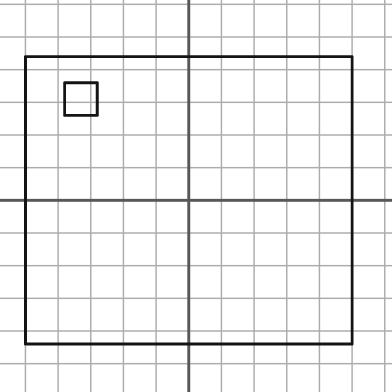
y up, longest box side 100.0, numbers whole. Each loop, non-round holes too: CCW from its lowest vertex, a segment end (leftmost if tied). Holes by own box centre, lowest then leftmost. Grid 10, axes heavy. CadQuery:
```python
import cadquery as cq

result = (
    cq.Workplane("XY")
    .moveTo(-50.0, -44.0)
    .lineTo(50.0, -44.0)
    .lineTo(50.0, 44.0)
    .lineTo(-50.0, 44.0)
    .close()
    .moveTo(-38.0, 26.0)
    .lineTo(-28.0, 26.0)
    .lineTo(-28.0, 36.0)
    .lineTo(-38.0, 36.0)
    .close()
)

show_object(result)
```